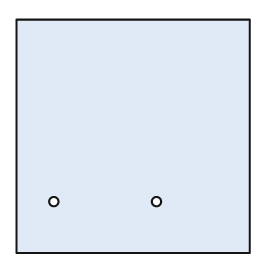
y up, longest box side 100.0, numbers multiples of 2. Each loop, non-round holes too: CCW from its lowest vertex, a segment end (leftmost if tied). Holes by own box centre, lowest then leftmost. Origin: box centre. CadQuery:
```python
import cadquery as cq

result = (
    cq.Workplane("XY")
    .moveTo(-50.0, -50.0)
    .lineTo(50.0, -50.0)
    .lineTo(50.0, 50.0)
    .lineTo(-50.0, 50.0)
    .close()
    .moveTo(-34.0, -28.0)
    .circle(2.0)
    .moveTo(10.0, -28.0)
    .circle(2.0)
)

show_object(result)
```